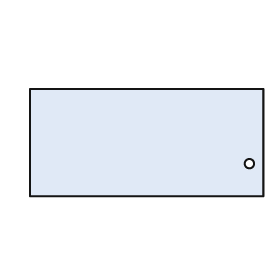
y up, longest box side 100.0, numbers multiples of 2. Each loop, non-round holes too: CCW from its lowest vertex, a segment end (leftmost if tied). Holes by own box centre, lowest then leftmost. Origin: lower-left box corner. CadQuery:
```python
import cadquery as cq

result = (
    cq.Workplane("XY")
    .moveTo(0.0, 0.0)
    .lineTo(100.0, 0.0)
    .lineTo(100.0, 46.0)
    .lineTo(0.0, 46.0)
    .close()
    .moveTo(94.0, 14.0)
    .circle(2.0)
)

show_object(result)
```